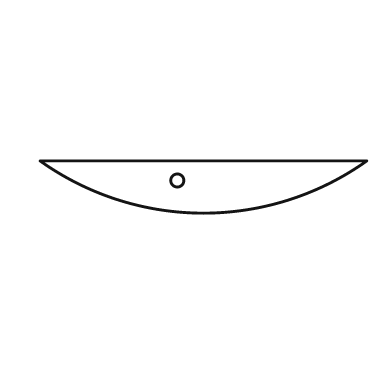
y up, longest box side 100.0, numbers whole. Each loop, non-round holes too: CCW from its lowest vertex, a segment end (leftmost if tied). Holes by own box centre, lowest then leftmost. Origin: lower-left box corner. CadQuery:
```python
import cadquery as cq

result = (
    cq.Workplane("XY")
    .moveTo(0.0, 16.0)
    .threePointArc((50.0, 0.0), (100.0, 16.0))
    .close()
    .moveTo(42.0, 10.0)
    .circle(2.0)
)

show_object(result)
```